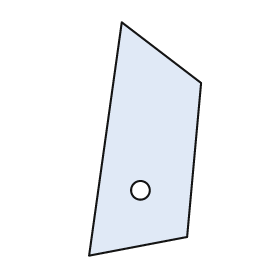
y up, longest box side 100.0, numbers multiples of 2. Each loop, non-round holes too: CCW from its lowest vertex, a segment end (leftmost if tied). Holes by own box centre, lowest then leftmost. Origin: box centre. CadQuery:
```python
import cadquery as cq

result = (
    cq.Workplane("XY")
    .moveTo(-24.0, -50.0)
    .lineTo(18.0, -42.0)
    .lineTo(24.0, 24.0)
    .lineTo(-10.0, 50.0)
    .close()
    .moveTo(-2.0, -22.0)
    .circle(4.0)
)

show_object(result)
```